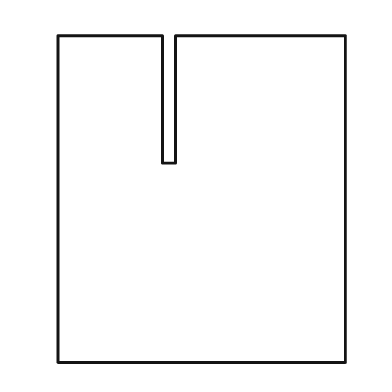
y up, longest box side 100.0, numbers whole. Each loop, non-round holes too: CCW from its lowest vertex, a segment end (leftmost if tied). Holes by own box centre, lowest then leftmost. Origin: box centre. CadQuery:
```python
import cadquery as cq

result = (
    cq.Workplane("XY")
    .moveTo(-44.0, -50.0)
    .lineTo(44.0, -50.0)
    .lineTo(44.0, 50.0)
    .lineTo(-8.0, 50.0)
    .lineTo(-8.0, 11.0)
    .lineTo(-12.0, 11.0)
    .lineTo(-12.0, 50.0)
    .lineTo(-44.0, 50.0)
    .close()
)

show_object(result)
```